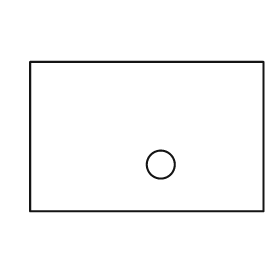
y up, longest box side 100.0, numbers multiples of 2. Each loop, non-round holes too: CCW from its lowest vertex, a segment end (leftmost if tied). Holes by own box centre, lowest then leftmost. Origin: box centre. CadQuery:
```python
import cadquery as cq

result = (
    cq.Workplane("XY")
    .moveTo(-50.0, -32.0)
    .lineTo(50.0, -32.0)
    .lineTo(50.0, 32.0)
    .lineTo(-50.0, 32.0)
    .close()
    .moveTo(6.0, -12.0)
    .circle(6.0)
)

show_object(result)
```